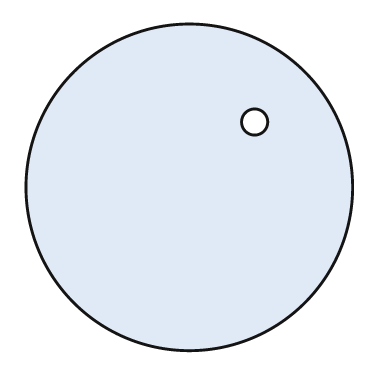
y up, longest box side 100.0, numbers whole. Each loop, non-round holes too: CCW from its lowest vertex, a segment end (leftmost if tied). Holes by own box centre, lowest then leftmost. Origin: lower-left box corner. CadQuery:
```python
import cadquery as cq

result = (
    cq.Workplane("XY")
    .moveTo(50.0, 50.0)
    .circle(50.0)
    .moveTo(70.0, 70.0)
    .circle(4.0)
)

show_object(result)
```